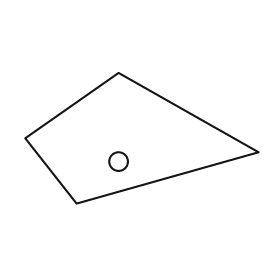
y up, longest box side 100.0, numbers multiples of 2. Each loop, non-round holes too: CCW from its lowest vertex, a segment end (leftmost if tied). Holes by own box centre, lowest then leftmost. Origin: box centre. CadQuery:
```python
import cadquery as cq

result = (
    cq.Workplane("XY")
    .moveTo(-28.0, -28.0)
    .lineTo(50.0, -6.0)
    .lineTo(-10.0, 28.0)
    .lineTo(-50.0, 0.0)
    .close()
    .moveTo(-10.0, -10.0)
    .circle(4.0)
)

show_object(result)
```